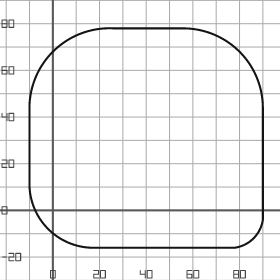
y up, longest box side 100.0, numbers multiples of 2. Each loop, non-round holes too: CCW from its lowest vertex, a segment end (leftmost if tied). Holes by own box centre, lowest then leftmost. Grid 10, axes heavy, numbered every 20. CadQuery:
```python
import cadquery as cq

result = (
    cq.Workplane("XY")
    .moveTo(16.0, -16.0)
    .lineTo(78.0, -16.0)
    .threePointArc((86.0, -12.0), (90.0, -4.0))
    .lineTo(90.0, 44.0)
    .threePointArc((80.0, 68.0), (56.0, 78.0))
    .lineTo(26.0, 78.0)
    .threePointArc((0.0, 68.0), (-10.0, 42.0))
    .lineTo(-10.0, 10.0)
    .threePointArc((-2.0, -8.0), (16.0, -16.0))
    .close()
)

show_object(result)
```